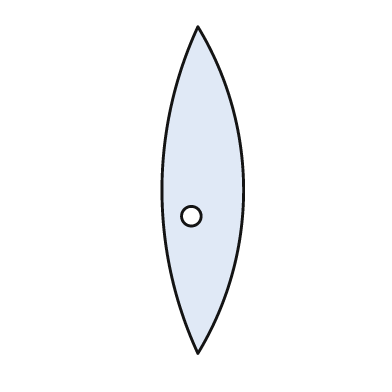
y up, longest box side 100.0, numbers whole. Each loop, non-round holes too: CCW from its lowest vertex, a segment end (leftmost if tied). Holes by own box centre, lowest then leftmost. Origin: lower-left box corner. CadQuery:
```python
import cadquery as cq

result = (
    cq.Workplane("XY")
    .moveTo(11.0, 0.0)
    .threePointArc((25.0, 50.0), (11.0, 100.0))
    .threePointArc((0.0, 50.0), (11.0, 0.0))
    .close()
    .moveTo(9.0, 42.0)
    .circle(3.0)
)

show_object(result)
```